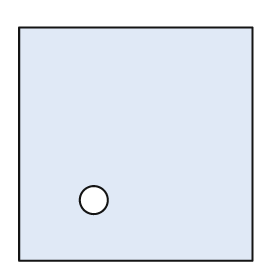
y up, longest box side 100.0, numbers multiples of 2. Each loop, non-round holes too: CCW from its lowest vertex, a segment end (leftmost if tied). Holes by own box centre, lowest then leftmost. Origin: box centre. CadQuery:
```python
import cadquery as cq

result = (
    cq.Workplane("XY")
    .moveTo(-50.0, -50.0)
    .lineTo(50.0, -50.0)
    .lineTo(50.0, 50.0)
    .lineTo(-50.0, 50.0)
    .close()
    .moveTo(-18.0, -24.0)
    .circle(6.0)
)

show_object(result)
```